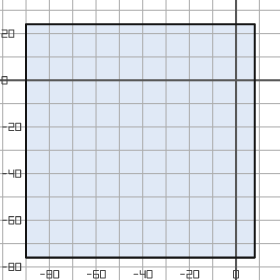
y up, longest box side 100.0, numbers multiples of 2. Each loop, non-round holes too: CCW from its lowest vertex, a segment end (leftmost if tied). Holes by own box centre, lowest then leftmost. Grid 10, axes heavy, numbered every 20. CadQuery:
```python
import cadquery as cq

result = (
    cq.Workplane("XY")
    .moveTo(-90.0, -76.0)
    .lineTo(8.0, -76.0)
    .lineTo(8.0, 24.0)
    .lineTo(-90.0, 24.0)
    .close()
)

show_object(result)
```